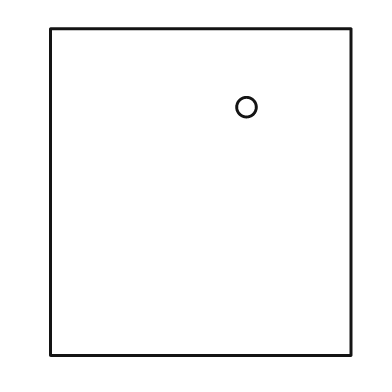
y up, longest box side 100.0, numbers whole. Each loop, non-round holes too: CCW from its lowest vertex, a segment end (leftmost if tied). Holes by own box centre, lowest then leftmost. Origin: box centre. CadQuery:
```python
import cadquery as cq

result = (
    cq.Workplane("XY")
    .moveTo(-46.0, -50.0)
    .lineTo(46.0, -50.0)
    .lineTo(46.0, 50.0)
    .lineTo(-46.0, 50.0)
    .close()
    .moveTo(14.0, 26.0)
    .circle(3.0)
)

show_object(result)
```